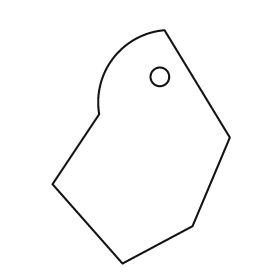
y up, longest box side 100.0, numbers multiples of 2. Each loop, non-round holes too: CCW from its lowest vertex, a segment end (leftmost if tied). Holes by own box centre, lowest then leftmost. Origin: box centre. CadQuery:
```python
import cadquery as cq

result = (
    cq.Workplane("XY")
    .moveTo(-8.0, -50.0)
    .lineTo(22.0, -34.0)
    .lineTo(38.0, 4.0)
    .lineTo(10.0, 50.0)
    .threePointArc((-12.0, 38.0), (-18.0, 14.0))
    .lineTo(-38.0, -16.0)
    .close()
    .moveTo(8.0, 30.0)
    .circle(4.0)
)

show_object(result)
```